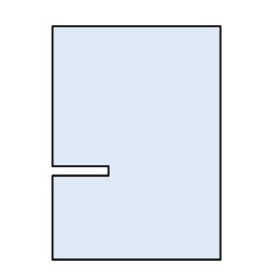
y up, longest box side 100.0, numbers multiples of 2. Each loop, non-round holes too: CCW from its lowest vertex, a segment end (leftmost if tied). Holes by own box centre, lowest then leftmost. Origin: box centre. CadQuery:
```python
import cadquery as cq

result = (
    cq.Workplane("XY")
    .moveTo(-36.0, -50.0)
    .lineTo(36.0, -50.0)
    .lineTo(36.0, 50.0)
    .lineTo(-36.0, 50.0)
    .lineTo(-36.0, -10.0)
    .lineTo(-12.0, -10.0)
    .lineTo(-12.0, -14.0)
    .lineTo(-36.0, -14.0)
    .close()
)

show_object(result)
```